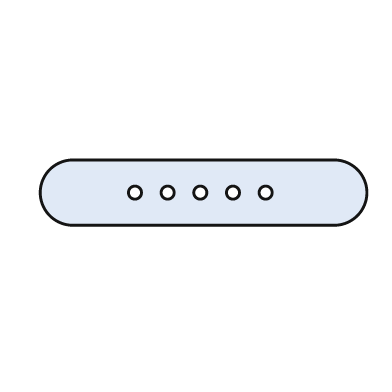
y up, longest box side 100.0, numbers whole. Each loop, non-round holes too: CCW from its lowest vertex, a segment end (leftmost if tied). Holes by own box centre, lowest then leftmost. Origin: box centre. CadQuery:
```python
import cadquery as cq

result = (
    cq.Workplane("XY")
    .moveTo(-40.0, -10.0)
    .lineTo(40.0, -10.0)
    .threePointArc((50.0, 0.0), (40.0, 10.0))
    .lineTo(-40.0, 10.0)
    .threePointArc((-50.0, 0.0), (-40.0, -10.0))
    .close()
    .moveTo(-21.0, 0.0)
    .circle(2.0)
    .moveTo(-11.0, 0.0)
    .circle(2.0)
    .moveTo(-1.0, 0.0)
    .circle(2.0)
    .moveTo(9.0, 0.0)
    .circle(2.0)
    .moveTo(19.0, 0.0)
    .circle(2.0)
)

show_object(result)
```